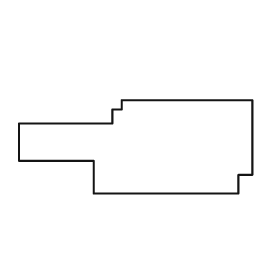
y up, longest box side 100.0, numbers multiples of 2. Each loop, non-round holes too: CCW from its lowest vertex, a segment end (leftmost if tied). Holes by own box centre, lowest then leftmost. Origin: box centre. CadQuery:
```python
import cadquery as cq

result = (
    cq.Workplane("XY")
    .moveTo(-18.0, -20.0)
    .lineTo(44.0, -20.0)
    .lineTo(44.0, -12.0)
    .lineTo(50.0, -12.0)
    .lineTo(50.0, 20.0)
    .lineTo(-6.0, 20.0)
    .lineTo(-6.0, 16.0)
    .lineTo(-10.0, 16.0)
    .lineTo(-10.0, 10.0)
    .lineTo(-50.0, 10.0)
    .lineTo(-50.0, -6.0)
    .lineTo(-18.0, -6.0)
    .close()
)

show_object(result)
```